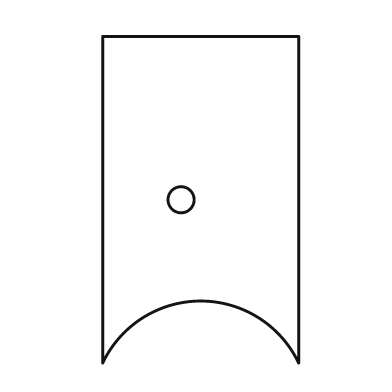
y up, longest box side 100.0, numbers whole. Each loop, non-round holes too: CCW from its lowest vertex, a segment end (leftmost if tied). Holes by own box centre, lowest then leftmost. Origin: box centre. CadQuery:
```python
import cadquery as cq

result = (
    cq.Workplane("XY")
    .moveTo(-30.0, -50.0)
    .threePointArc((0.0, -31.0), (30.0, -50.0))
    .lineTo(30.0, 50.0)
    .lineTo(-30.0, 50.0)
    .close()
    .moveTo(-6.0, 0.0)
    .circle(4.0)
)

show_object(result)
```